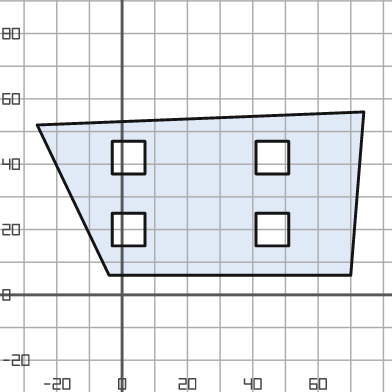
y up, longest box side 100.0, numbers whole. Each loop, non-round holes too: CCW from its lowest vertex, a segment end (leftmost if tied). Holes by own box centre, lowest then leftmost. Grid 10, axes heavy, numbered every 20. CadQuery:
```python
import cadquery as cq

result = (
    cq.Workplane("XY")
    .moveTo(-4.0, 6.0)
    .lineTo(70.0, 6.0)
    .lineTo(74.0, 56.0)
    .lineTo(-26.0, 52.0)
    .close()
    .moveTo(-3.0, 15.0)
    .lineTo(7.0, 15.0)
    .lineTo(7.0, 25.0)
    .lineTo(-3.0, 25.0)
    .close()
    .moveTo(41.0, 15.0)
    .lineTo(51.0, 15.0)
    .lineTo(51.0, 25.0)
    .lineTo(41.0, 25.0)
    .close()
    .moveTo(-3.0, 37.0)
    .lineTo(7.0, 37.0)
    .lineTo(7.0, 47.0)
    .lineTo(-3.0, 47.0)
    .close()
    .moveTo(41.0, 37.0)
    .lineTo(51.0, 37.0)
    .lineTo(51.0, 47.0)
    .lineTo(41.0, 47.0)
    .close()
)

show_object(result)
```